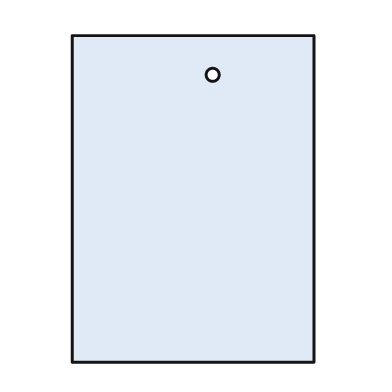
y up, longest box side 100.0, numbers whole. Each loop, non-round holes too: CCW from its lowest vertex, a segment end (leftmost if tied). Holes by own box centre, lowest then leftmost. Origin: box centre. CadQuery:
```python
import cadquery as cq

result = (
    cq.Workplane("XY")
    .moveTo(-37.0, -50.0)
    .lineTo(37.0, -50.0)
    .lineTo(37.0, 50.0)
    .lineTo(-37.0, 50.0)
    .close()
    .moveTo(6.0, 38.0)
    .circle(2.0)
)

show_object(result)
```